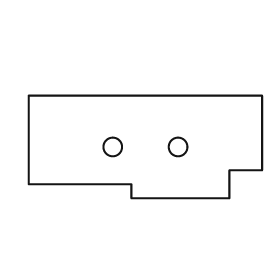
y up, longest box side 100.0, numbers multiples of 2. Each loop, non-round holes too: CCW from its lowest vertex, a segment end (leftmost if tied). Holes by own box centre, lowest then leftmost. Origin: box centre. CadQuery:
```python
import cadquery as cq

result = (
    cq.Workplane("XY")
    .moveTo(-6.0, -22.0)
    .lineTo(36.0, -22.0)
    .lineTo(36.0, -10.0)
    .lineTo(50.0, -10.0)
    .lineTo(50.0, 22.0)
    .lineTo(-50.0, 22.0)
    .lineTo(-50.0, -16.0)
    .lineTo(-6.0, -16.0)
    .close()
    .moveTo(-14.0, 0.0)
    .circle(4.0)
    .moveTo(14.0, 0.0)
    .circle(4.0)
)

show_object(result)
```